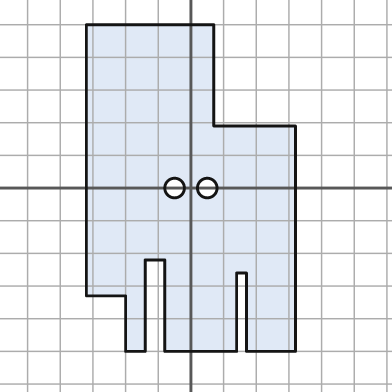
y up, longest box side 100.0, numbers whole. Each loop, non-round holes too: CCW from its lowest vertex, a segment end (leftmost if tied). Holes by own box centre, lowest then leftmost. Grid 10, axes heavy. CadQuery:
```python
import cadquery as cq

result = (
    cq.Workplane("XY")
    .moveTo(-20.0, -50.0)
    .lineTo(-14.0, -50.0)
    .lineTo(-14.0, -22.0)
    .lineTo(-8.0, -22.0)
    .lineTo(-8.0, -50.0)
    .lineTo(14.0, -50.0)
    .lineTo(14.0, -26.0)
    .lineTo(17.0, -26.0)
    .lineTo(17.0, -50.0)
    .lineTo(32.0, -50.0)
    .lineTo(32.0, 19.0)
    .lineTo(7.0, 19.0)
    .lineTo(7.0, 50.0)
    .lineTo(-32.0, 50.0)
    .lineTo(-32.0, -33.0)
    .lineTo(-20.0, -33.0)
    .close()
    .moveTo(-5.0, 0.0)
    .circle(3.0)
    .moveTo(5.0, 0.0)
    .circle(3.0)
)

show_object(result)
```